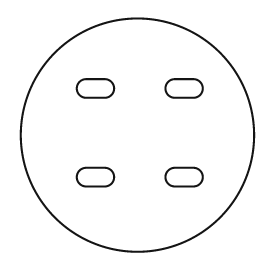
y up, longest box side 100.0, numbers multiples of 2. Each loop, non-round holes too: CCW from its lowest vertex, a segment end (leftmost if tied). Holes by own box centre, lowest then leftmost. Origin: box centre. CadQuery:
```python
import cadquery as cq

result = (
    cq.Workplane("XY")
    .moveTo(0.0, 0.0)
    .circle(50.0)
    .moveTo(-22.0, -22.0)
    .lineTo(-14.0, -22.0)
    .threePointArc((-10.0, -18.0), (-14.0, -14.0))
    .lineTo(-22.0, -14.0)
    .threePointArc((-26.0, -18.0), (-22.0, -22.0))
    .close()
    .moveTo(16.0, -22.0)
    .lineTo(24.0, -22.0)
    .threePointArc((28.0, -18.0), (24.0, -14.0))
    .lineTo(16.0, -14.0)
    .threePointArc((12.0, -18.0), (16.0, -22.0))
    .close()
    .moveTo(-22.0, 16.0)
    .lineTo(-14.0, 16.0)
    .threePointArc((-10.0, 20.0), (-14.0, 24.0))
    .lineTo(-22.0, 24.0)
    .threePointArc((-26.0, 20.0), (-22.0, 16.0))
    .close()
    .moveTo(16.0, 16.0)
    .lineTo(24.0, 16.0)
    .threePointArc((28.0, 20.0), (24.0, 24.0))
    .lineTo(16.0, 24.0)
    .threePointArc((12.0, 20.0), (16.0, 16.0))
    .close()
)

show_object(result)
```